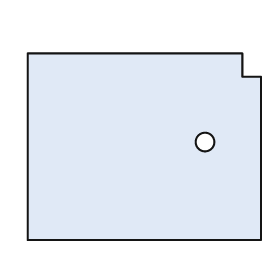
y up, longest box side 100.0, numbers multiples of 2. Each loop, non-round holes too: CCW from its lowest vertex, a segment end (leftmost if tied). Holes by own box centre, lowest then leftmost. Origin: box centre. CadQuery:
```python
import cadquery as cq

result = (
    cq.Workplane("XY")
    .moveTo(-50.0, -40.0)
    .lineTo(50.0, -40.0)
    .lineTo(50.0, 30.0)
    .lineTo(42.0, 30.0)
    .lineTo(42.0, 40.0)
    .lineTo(-50.0, 40.0)
    .close()
    .moveTo(26.0, 2.0)
    .circle(4.0)
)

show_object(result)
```